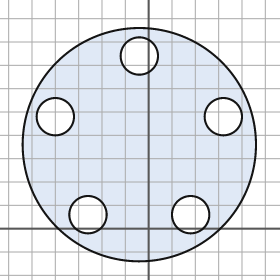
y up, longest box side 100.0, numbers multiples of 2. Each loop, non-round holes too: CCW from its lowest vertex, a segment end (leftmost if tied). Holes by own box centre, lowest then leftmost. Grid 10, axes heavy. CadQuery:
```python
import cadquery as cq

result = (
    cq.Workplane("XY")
    .moveTo(-4.0, 36.0)
    .circle(50.0)
    .moveTo(-26.0, 6.0)
    .circle(8.0)
    .moveTo(18.0, 6.0)
    .circle(8.0)
    .moveTo(-40.0, 48.0)
    .circle(8.0)
    .moveTo(32.0, 48.0)
    .circle(8.0)
    .moveTo(-4.0, 74.0)
    .circle(8.0)
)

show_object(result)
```